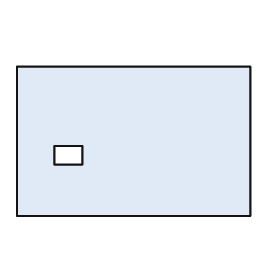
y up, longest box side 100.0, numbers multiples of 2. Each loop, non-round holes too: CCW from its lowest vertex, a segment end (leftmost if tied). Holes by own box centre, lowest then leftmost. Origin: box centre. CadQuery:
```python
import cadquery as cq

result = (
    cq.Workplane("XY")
    .moveTo(-50.0, -32.0)
    .lineTo(50.0, -32.0)
    .lineTo(50.0, 32.0)
    .lineTo(-50.0, 32.0)
    .close()
    .moveTo(-34.0, -10.0)
    .lineTo(-22.0, -10.0)
    .lineTo(-22.0, -2.0)
    .lineTo(-34.0, -2.0)
    .close()
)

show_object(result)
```